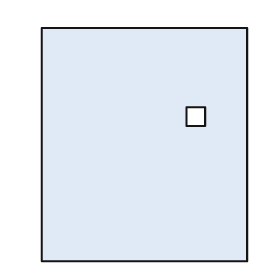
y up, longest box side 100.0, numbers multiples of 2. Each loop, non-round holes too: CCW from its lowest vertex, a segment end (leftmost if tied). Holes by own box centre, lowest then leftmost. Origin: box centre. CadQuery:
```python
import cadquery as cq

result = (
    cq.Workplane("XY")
    .moveTo(-44.0, -50.0)
    .lineTo(44.0, -50.0)
    .lineTo(44.0, 50.0)
    .lineTo(-44.0, 50.0)
    .close()
    .moveTo(18.0, 8.0)
    .lineTo(26.0, 8.0)
    .lineTo(26.0, 16.0)
    .lineTo(18.0, 16.0)
    .close()
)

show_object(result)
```